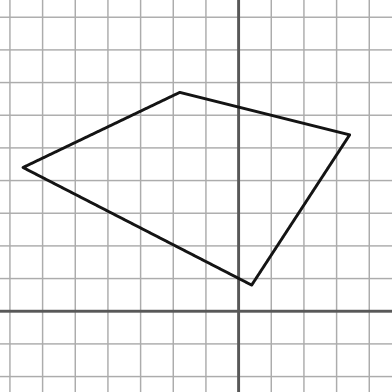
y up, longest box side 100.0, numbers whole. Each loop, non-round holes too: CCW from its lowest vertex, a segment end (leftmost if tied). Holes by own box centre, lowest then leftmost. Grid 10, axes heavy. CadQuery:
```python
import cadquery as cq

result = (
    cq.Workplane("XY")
    .moveTo(4.0, 8.0)
    .lineTo(34.0, 54.0)
    .lineTo(-18.0, 67.0)
    .lineTo(-66.0, 44.0)
    .close()
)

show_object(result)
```